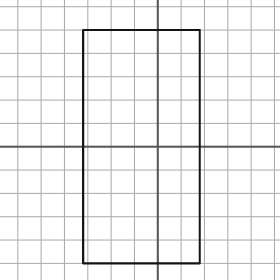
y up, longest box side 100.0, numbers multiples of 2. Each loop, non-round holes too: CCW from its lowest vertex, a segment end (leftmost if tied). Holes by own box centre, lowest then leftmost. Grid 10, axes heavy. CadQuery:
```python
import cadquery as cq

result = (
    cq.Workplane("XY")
    .moveTo(-32.0, -50.0)
    .lineTo(18.0, -50.0)
    .lineTo(18.0, 50.0)
    .lineTo(-32.0, 50.0)
    .close()
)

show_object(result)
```